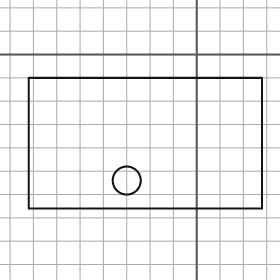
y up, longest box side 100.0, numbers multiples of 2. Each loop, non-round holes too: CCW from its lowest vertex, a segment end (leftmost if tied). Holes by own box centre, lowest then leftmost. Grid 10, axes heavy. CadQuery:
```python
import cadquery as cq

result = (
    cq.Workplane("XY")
    .moveTo(-72.0, -66.0)
    .lineTo(28.0, -66.0)
    .lineTo(28.0, -10.0)
    .lineTo(-72.0, -10.0)
    .close()
    .moveTo(-30.0, -54.0)
    .circle(6.0)
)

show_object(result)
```